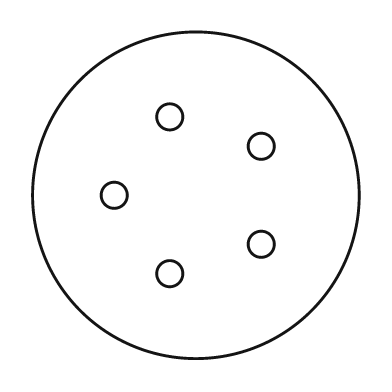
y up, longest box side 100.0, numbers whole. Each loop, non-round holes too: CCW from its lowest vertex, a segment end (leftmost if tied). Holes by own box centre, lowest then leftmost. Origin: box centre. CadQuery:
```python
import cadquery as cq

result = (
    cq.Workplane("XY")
    .moveTo(0.0, 0.0)
    .circle(50.0)
    .moveTo(-8.0, -24.0)
    .circle(4.0)
    .moveTo(20.0, -15.0)
    .circle(4.0)
    .moveTo(-25.0, 0.0)
    .circle(4.0)
    .moveTo(20.0, 15.0)
    .circle(4.0)
    .moveTo(-8.0, 24.0)
    .circle(4.0)
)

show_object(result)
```